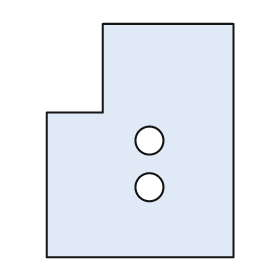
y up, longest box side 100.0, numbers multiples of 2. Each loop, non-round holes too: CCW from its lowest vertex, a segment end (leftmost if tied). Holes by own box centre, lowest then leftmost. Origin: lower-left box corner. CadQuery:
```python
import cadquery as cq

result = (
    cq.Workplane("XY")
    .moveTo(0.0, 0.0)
    .lineTo(80.0, 0.0)
    .lineTo(80.0, 100.0)
    .lineTo(24.0, 100.0)
    .lineTo(24.0, 62.0)
    .lineTo(0.0, 62.0)
    .close()
    .moveTo(44.0, 30.0)
    .circle(6.0)
    .moveTo(44.0, 50.0)
    .circle(6.0)
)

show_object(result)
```